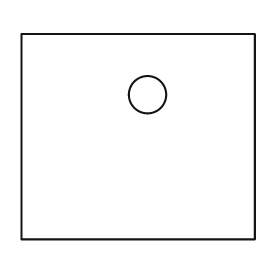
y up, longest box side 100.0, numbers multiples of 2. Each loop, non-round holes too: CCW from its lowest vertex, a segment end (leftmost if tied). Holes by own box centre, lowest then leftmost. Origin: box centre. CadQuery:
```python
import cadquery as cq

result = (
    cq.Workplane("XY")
    .moveTo(-50.0, -44.0)
    .lineTo(50.0, -44.0)
    .lineTo(50.0, 44.0)
    .lineTo(-50.0, 44.0)
    .close()
    .moveTo(4.0, 18.0)
    .circle(8.0)
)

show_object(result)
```